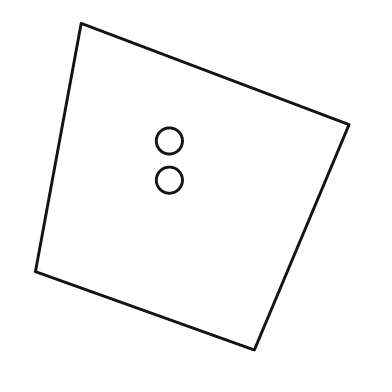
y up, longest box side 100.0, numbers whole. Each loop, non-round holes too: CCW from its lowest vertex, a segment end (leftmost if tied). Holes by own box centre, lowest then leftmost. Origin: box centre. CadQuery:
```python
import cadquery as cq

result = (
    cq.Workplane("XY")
    .moveTo(19.0, -50.0)
    .lineTo(48.0, 19.0)
    .lineTo(-34.0, 50.0)
    .lineTo(-48.0, -26.0)
    .close()
    .moveTo(-7.0, 2.0)
    .circle(4.0)
    .moveTo(-7.0, 14.0)
    .circle(4.0)
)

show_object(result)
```